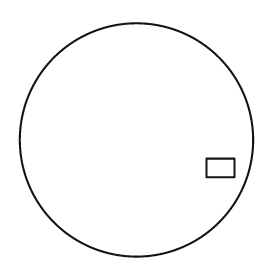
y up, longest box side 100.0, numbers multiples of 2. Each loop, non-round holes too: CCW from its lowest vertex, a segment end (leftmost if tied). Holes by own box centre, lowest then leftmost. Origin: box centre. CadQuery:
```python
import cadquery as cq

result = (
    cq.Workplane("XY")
    .moveTo(0.0, 0.0)
    .circle(50.0)
    .moveTo(30.0, -16.0)
    .lineTo(42.0, -16.0)
    .lineTo(42.0, -8.0)
    .lineTo(30.0, -8.0)
    .close()
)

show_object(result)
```